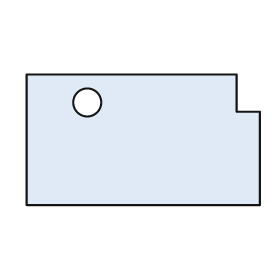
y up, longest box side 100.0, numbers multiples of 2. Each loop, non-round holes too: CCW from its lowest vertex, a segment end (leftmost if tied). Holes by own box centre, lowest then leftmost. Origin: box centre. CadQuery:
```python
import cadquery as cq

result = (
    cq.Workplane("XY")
    .moveTo(-50.0, -28.0)
    .lineTo(50.0, -28.0)
    .lineTo(50.0, 12.0)
    .lineTo(40.0, 12.0)
    .lineTo(40.0, 28.0)
    .lineTo(-50.0, 28.0)
    .close()
    .moveTo(-24.0, 16.0)
    .circle(6.0)
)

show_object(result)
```